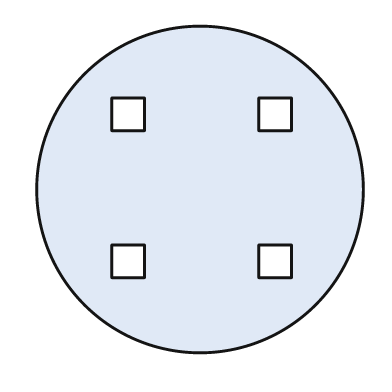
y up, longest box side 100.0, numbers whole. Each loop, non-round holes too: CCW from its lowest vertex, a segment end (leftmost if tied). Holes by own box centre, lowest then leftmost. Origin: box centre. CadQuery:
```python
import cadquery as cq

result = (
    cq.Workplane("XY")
    .moveTo(0.0, 0.0)
    .circle(50.0)
    .moveTo(-27.0, -27.0)
    .lineTo(-17.0, -27.0)
    .lineTo(-17.0, -17.0)
    .lineTo(-27.0, -17.0)
    .close()
    .moveTo(18.0, -27.0)
    .lineTo(28.0, -27.0)
    .lineTo(28.0, -17.0)
    .lineTo(18.0, -17.0)
    .close()
    .moveTo(-27.0, 18.0)
    .lineTo(-17.0, 18.0)
    .lineTo(-17.0, 28.0)
    .lineTo(-27.0, 28.0)
    .close()
    .moveTo(18.0, 18.0)
    .lineTo(28.0, 18.0)
    .lineTo(28.0, 28.0)
    .lineTo(18.0, 28.0)
    .close()
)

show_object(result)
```